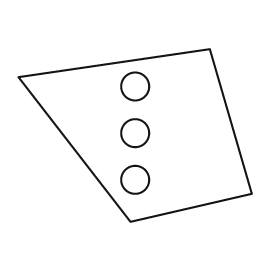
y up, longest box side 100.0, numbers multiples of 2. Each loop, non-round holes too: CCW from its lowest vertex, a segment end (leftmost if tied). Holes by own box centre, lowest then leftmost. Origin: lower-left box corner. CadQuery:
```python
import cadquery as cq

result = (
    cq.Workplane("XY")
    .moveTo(48.0, 0.0)
    .lineTo(100.0, 12.0)
    .lineTo(82.0, 74.0)
    .lineTo(0.0, 62.0)
    .close()
    .moveTo(50.0, 18.0)
    .circle(6.0)
    .moveTo(50.0, 38.0)
    .circle(6.0)
    .moveTo(50.0, 58.0)
    .circle(6.0)
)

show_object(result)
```